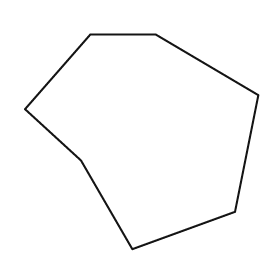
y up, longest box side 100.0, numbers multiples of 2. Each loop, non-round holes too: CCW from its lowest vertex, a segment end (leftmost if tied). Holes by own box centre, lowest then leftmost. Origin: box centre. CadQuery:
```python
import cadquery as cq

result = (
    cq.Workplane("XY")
    .moveTo(-4.0, -46.0)
    .lineTo(40.0, -30.0)
    .lineTo(50.0, 20.0)
    .lineTo(6.0, 46.0)
    .lineTo(-22.0, 46.0)
    .lineTo(-50.0, 14.0)
    .lineTo(-26.0, -8.0)
    .close()
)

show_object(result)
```